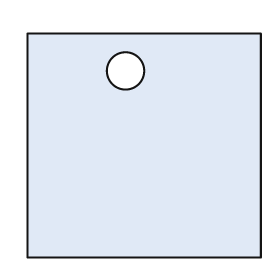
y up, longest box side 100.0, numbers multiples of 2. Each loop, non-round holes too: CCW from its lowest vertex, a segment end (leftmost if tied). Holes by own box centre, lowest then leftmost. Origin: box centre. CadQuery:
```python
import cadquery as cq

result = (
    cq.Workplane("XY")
    .moveTo(-50.0, -48.0)
    .lineTo(50.0, -48.0)
    .lineTo(50.0, 48.0)
    .lineTo(-50.0, 48.0)
    .close()
    .moveTo(-8.0, 32.0)
    .circle(8.0)
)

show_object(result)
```